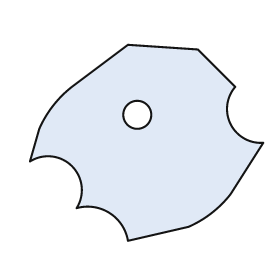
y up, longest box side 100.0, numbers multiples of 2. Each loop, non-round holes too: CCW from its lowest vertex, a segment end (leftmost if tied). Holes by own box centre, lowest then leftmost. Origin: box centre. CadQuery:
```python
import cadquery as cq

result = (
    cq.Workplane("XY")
    .moveTo(-8.0, -42.0)
    .lineTo(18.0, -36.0)
    .threePointArc((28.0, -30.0), (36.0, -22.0))
    .lineTo(50.0, 0.0)
    .threePointArc((36.0, 8.0), (38.0, 24.0))
    .lineTo(22.0, 40.0)
    .lineTo(-8.0, 42.0)
    .lineTo(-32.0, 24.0)
    .threePointArc((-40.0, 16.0), (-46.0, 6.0))
    .lineTo(-50.0, -8.0)
    .threePointArc((-32.0, -10.0), (-30.0, -28.0))
    .threePointArc((-16.0, -30.0), (-8.0, -42.0))
    .close()
    .moveTo(-4.0, 12.0)
    .circle(6.0)
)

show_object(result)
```